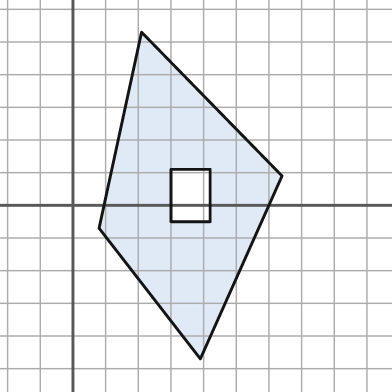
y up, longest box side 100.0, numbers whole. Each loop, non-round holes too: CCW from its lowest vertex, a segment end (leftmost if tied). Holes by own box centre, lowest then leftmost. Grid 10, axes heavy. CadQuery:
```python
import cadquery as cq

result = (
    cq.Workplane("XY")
    .moveTo(39.0, -47.0)
    .lineTo(64.0, 9.0)
    .lineTo(21.0, 53.0)
    .lineTo(8.0, -7.0)
    .close()
    .moveTo(30.0, -5.0)
    .lineTo(42.0, -5.0)
    .lineTo(42.0, 11.0)
    .lineTo(30.0, 11.0)
    .close()
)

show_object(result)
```